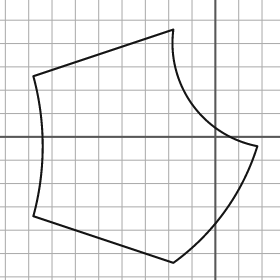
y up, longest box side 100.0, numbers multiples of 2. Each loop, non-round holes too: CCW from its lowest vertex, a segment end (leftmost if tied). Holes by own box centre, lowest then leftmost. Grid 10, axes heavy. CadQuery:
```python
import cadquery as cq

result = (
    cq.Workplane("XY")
    .moveTo(-18.0, -54.0)
    .threePointArc((4.0, -32.0), (18.0, -4.0))
    .threePointArc((-10.0, 14.0), (-18.0, 46.0))
    .lineTo(-78.0, 26.0)
    .threePointArc((-74.0, -4.0), (-78.0, -34.0))
    .close()
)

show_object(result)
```